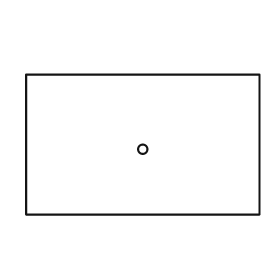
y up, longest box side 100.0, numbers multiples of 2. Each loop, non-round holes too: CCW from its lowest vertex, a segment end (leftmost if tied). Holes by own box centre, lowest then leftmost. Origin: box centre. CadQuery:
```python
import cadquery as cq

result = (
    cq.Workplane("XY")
    .moveTo(-50.0, -30.0)
    .lineTo(50.0, -30.0)
    .lineTo(50.0, 30.0)
    .lineTo(-50.0, 30.0)
    .close()
    .moveTo(0.0, -2.0)
    .circle(2.0)
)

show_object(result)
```